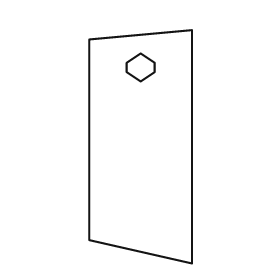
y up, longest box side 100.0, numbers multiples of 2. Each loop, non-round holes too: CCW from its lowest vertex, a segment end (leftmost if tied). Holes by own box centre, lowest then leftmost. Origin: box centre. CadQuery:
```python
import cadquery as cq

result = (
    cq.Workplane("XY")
    .moveTo(22.0, -50.0)
    .lineTo(22.0, 50.0)
    .lineTo(-22.0, 46.0)
    .lineTo(-22.0, -40.0)
    .close()
    .moveTo(0.0, 28.0)
    .lineTo(6.0, 32.0)
    .lineTo(6.0, 36.0)
    .lineTo(0.0, 40.0)
    .lineTo(-6.0, 36.0)
    .lineTo(-6.0, 32.0)
    .close()
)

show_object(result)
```